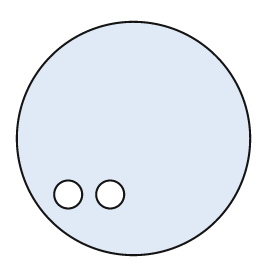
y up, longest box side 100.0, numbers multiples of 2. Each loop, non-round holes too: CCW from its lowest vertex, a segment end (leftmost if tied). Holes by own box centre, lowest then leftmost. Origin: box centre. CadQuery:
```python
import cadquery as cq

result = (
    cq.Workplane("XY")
    .moveTo(0.0, 0.0)
    .circle(50.0)
    .moveTo(-28.0, -24.0)
    .circle(6.0)
    .moveTo(-10.0, -24.0)
    .circle(6.0)
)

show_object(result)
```